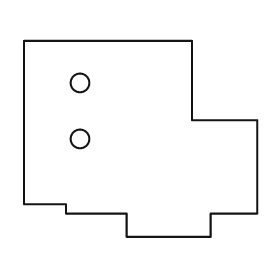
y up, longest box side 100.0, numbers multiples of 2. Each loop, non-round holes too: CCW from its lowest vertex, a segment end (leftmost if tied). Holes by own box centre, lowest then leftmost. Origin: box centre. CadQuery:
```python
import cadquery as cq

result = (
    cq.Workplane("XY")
    .moveTo(-6.0, -42.0)
    .lineTo(30.0, -42.0)
    .lineTo(30.0, -32.0)
    .lineTo(50.0, -32.0)
    .lineTo(50.0, 8.0)
    .lineTo(22.0, 8.0)
    .lineTo(22.0, 42.0)
    .lineTo(-50.0, 42.0)
    .lineTo(-50.0, -28.0)
    .lineTo(-32.0, -28.0)
    .lineTo(-32.0, -32.0)
    .lineTo(-6.0, -32.0)
    .close()
    .moveTo(-26.0, 0.0)
    .circle(4.0)
    .moveTo(-26.0, 24.0)
    .circle(4.0)
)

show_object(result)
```